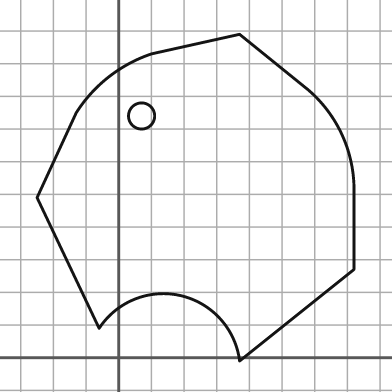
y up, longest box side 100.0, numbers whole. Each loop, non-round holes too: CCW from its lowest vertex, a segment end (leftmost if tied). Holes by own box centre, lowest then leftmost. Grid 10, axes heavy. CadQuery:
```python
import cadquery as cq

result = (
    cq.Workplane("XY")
    .moveTo(37.0, -1.0)
    .lineTo(72.0, 27.0)
    .lineTo(72.0, 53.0)
    .threePointArc((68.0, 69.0), (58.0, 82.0))
    .lineTo(37.0, 99.0)
    .lineTo(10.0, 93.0)
    .threePointArc((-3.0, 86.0), (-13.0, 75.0))
    .lineTo(-25.0, 49.0)
    .lineTo(-6.0, 9.0)
    .threePointArc((19.0, 19.0), (37.0, -1.0))
    .close()
    .moveTo(7.0, 74.0)
    .circle(4.0)
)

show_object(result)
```